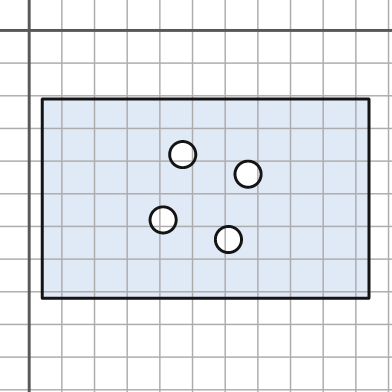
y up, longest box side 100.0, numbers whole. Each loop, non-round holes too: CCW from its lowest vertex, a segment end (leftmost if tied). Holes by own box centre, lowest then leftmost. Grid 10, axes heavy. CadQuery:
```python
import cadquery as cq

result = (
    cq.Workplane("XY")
    .moveTo(4.0, -82.0)
    .lineTo(104.0, -82.0)
    .lineTo(104.0, -21.0)
    .lineTo(4.0, -21.0)
    .close()
    .moveTo(61.0, -64.0)
    .circle(4.0)
    .moveTo(41.0, -58.0)
    .circle(4.0)
    .moveTo(67.0, -44.0)
    .circle(4.0)
    .moveTo(47.0, -38.0)
    .circle(4.0)
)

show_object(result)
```